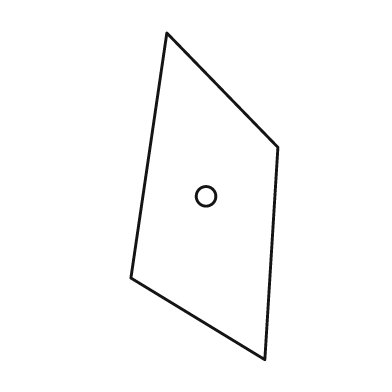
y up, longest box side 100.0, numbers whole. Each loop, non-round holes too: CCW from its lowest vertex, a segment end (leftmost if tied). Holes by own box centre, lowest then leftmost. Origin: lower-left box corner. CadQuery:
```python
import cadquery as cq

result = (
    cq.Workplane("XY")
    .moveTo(41.0, 0.0)
    .lineTo(45.0, 65.0)
    .lineTo(11.0, 100.0)
    .lineTo(0.0, 25.0)
    .close()
    .moveTo(23.0, 50.0)
    .circle(3.0)
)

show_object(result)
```